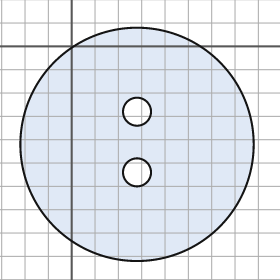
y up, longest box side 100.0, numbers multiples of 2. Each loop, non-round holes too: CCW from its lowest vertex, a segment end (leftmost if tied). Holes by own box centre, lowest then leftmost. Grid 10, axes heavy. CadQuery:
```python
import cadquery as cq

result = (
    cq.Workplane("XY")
    .moveTo(28.0, -42.0)
    .circle(50.0)
    .moveTo(28.0, -54.0)
    .circle(6.0)
    .moveTo(28.0, -28.0)
    .circle(6.0)
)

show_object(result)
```